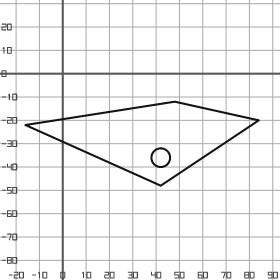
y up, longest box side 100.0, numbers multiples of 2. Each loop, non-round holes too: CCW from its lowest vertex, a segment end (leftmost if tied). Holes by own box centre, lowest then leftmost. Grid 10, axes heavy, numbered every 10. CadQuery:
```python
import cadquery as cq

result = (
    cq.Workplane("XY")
    .moveTo(42.0, -48.0)
    .lineTo(84.0, -20.0)
    .lineTo(48.0, -12.0)
    .lineTo(-16.0, -22.0)
    .close()
    .moveTo(42.0, -36.0)
    .circle(4.0)
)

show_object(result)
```